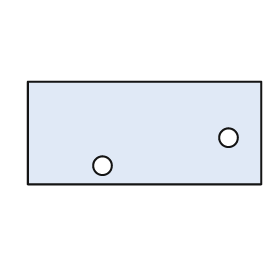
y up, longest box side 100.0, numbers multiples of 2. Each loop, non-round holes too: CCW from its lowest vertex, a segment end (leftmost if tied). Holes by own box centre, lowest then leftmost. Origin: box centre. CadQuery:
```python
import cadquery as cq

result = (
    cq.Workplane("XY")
    .moveTo(-50.0, -22.0)
    .lineTo(50.0, -22.0)
    .lineTo(50.0, 22.0)
    .lineTo(-50.0, 22.0)
    .close()
    .moveTo(-18.0, -14.0)
    .circle(4.0)
    .moveTo(36.0, -2.0)
    .circle(4.0)
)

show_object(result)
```